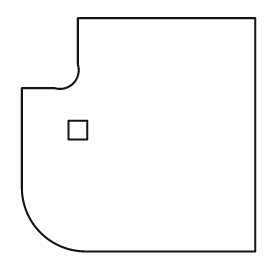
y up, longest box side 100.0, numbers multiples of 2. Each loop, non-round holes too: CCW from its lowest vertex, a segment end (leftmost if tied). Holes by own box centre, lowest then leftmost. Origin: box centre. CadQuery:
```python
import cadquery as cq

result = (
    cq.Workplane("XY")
    .moveTo(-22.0, -50.0)
    .lineTo(50.0, -50.0)
    .lineTo(50.0, 50.0)
    .lineTo(-26.0, 50.0)
    .lineTo(-26.0, 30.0)
    .threePointArc((-28.0, 22.0), (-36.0, 20.0))
    .lineTo(-50.0, 20.0)
    .lineTo(-50.0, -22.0)
    .threePointArc((-42.0, -42.0), (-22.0, -50.0))
    .close()
    .moveTo(-30.0, -2.0)
    .lineTo(-22.0, -2.0)
    .lineTo(-22.0, 6.0)
    .lineTo(-30.0, 6.0)
    .close()
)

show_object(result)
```